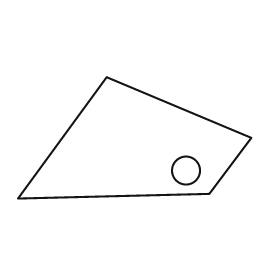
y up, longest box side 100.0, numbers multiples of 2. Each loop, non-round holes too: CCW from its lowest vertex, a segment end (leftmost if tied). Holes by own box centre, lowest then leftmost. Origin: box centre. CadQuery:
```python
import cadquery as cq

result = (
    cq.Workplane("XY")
    .moveTo(-50.0, -26.0)
    .lineTo(32.0, -24.0)
    .lineTo(50.0, 0.0)
    .lineTo(-12.0, 26.0)
    .close()
    .moveTo(22.0, -14.0)
    .circle(6.0)
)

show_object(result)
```